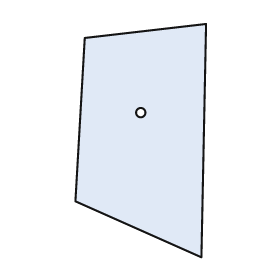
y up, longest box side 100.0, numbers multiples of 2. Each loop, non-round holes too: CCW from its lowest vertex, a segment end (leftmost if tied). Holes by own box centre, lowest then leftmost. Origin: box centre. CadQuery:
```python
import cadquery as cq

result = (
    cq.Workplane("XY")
    .moveTo(26.0, -50.0)
    .lineTo(28.0, 50.0)
    .lineTo(-24.0, 44.0)
    .lineTo(-28.0, -26.0)
    .close()
    .moveTo(0.0, 12.0)
    .circle(2.0)
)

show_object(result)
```